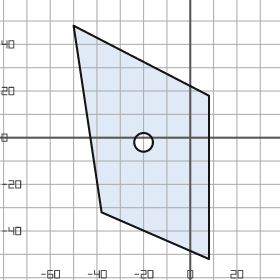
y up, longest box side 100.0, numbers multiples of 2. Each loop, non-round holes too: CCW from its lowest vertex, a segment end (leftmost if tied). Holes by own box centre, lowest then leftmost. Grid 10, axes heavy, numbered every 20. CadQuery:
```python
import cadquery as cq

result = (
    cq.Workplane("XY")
    .moveTo(8.0, -52.0)
    .lineTo(8.0, 18.0)
    .lineTo(-50.0, 48.0)
    .lineTo(-38.0, -32.0)
    .close()
    .moveTo(-20.0, -2.0)
    .circle(4.0)
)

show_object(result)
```